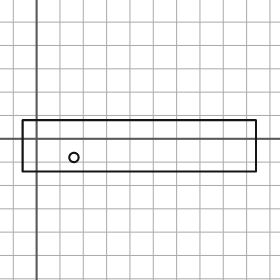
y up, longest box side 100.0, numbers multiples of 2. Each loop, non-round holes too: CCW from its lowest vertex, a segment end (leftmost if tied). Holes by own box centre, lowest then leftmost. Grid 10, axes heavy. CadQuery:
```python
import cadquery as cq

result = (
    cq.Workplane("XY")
    .moveTo(-6.0, -14.0)
    .lineTo(94.0, -14.0)
    .lineTo(94.0, 8.0)
    .lineTo(-6.0, 8.0)
    .close()
    .moveTo(16.0, -8.0)
    .circle(2.0)
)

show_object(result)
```